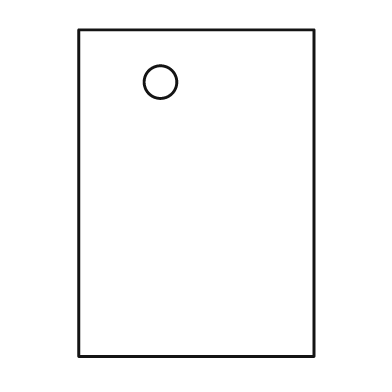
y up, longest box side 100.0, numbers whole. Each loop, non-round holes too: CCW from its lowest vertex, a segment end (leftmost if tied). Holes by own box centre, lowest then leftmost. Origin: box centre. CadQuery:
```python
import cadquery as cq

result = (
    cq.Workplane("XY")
    .moveTo(-36.0, -50.0)
    .lineTo(36.0, -50.0)
    .lineTo(36.0, 50.0)
    .lineTo(-36.0, 50.0)
    .close()
    .moveTo(-11.0, 34.0)
    .circle(5.0)
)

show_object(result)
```